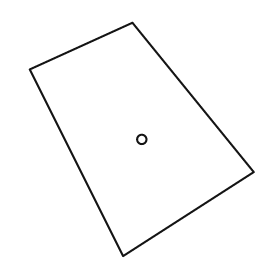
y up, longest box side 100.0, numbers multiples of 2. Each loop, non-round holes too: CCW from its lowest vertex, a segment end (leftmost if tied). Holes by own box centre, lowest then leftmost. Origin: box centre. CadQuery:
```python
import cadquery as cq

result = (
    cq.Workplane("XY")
    .moveTo(-8.0, -50.0)
    .lineTo(48.0, -14.0)
    .lineTo(-4.0, 50.0)
    .lineTo(-48.0, 30.0)
    .close()
    .moveTo(0.0, 0.0)
    .circle(2.0)
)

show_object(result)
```